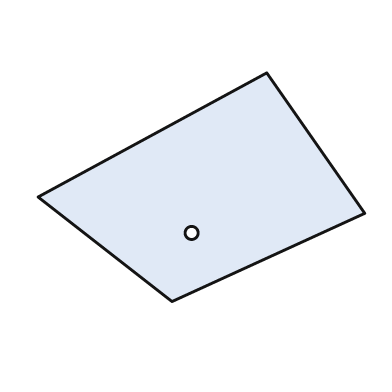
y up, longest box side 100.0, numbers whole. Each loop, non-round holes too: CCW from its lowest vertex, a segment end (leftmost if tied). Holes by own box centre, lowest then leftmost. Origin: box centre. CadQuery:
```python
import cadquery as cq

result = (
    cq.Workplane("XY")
    .moveTo(-9.0, -35.0)
    .lineTo(50.0, -8.0)
    .lineTo(20.0, 35.0)
    .lineTo(-50.0, -3.0)
    .close()
    .moveTo(-3.0, -14.0)
    .circle(2.0)
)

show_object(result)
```